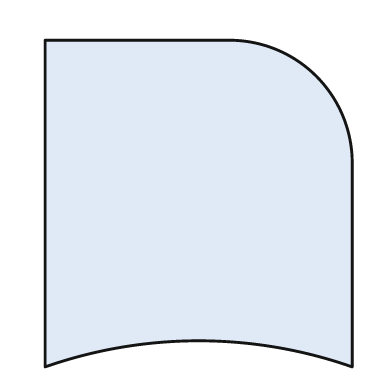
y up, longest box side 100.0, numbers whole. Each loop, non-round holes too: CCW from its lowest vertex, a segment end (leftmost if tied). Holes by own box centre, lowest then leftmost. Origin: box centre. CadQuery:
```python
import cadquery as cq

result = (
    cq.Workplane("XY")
    .moveTo(-47.0, -50.0)
    .threePointArc((0.0, -42.0), (47.0, -50.0))
    .lineTo(47.0, 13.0)
    .threePointArc((36.0, 39.0), (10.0, 50.0))
    .lineTo(-47.0, 50.0)
    .close()
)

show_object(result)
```